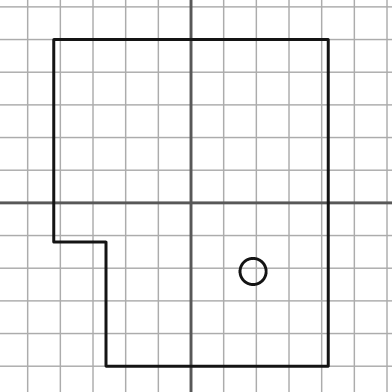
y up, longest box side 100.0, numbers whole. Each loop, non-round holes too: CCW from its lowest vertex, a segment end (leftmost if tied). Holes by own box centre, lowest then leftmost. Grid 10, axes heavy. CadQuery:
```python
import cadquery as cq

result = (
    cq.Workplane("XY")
    .moveTo(-26.0, -50.0)
    .lineTo(42.0, -50.0)
    .lineTo(42.0, 50.0)
    .lineTo(-42.0, 50.0)
    .lineTo(-42.0, -12.0)
    .lineTo(-26.0, -12.0)
    .close()
    .moveTo(19.0, -21.0)
    .circle(4.0)
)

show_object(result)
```